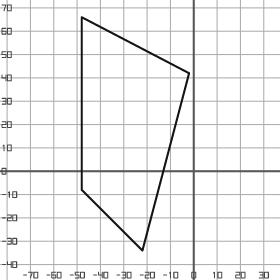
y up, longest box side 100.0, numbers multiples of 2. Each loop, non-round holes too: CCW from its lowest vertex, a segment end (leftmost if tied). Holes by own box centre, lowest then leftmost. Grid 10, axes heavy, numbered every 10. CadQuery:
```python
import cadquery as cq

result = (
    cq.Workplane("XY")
    .moveTo(-22.0, -34.0)
    .lineTo(-2.0, 42.0)
    .lineTo(-48.0, 66.0)
    .lineTo(-48.0, -8.0)
    .close()
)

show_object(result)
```